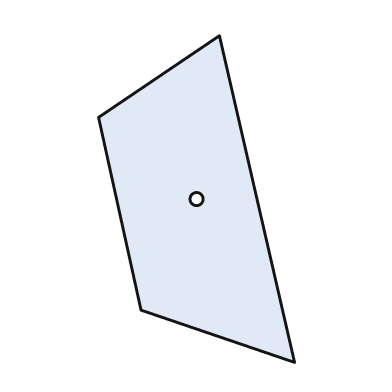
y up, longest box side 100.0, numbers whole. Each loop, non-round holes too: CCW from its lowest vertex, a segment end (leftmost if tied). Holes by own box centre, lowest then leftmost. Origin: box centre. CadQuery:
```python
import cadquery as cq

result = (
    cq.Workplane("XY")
    .moveTo(30.0, -50.0)
    .lineTo(7.0, 50.0)
    .lineTo(-30.0, 25.0)
    .lineTo(-17.0, -34.0)
    .close()
    .moveTo(0.0, 0.0)
    .circle(2.0)
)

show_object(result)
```